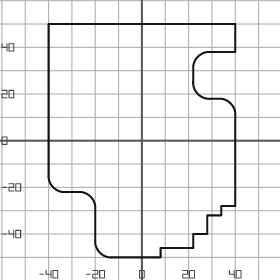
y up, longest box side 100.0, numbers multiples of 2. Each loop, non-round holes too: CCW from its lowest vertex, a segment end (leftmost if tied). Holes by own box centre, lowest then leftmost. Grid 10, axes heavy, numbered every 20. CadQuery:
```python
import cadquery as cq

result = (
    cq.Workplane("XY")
    .moveTo(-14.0, -50.0)
    .lineTo(8.0, -50.0)
    .lineTo(8.0, -46.0)
    .lineTo(22.0, -46.0)
    .lineTo(22.0, -40.0)
    .lineTo(28.0, -40.0)
    .lineTo(28.0, -32.0)
    .lineTo(34.0, -32.0)
    .lineTo(34.0, -28.0)
    .lineTo(40.0, -28.0)
    .lineTo(40.0, 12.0)
    .threePointArc((38.0, 16.0), (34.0, 18.0))
    .lineTo(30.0, 18.0)
    .threePointArc((24.0, 20.0), (22.0, 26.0))
    .lineTo(22.0, 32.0)
    .threePointArc((24.0, 36.0), (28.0, 38.0))
    .lineTo(40.0, 38.0)
    .lineTo(40.0, 50.0)
    .lineTo(-40.0, 50.0)
    .lineTo(-40.0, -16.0)
    .threePointArc((-38.0, -20.0), (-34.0, -22.0))
    .lineTo(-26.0, -22.0)
    .threePointArc((-22.0, -24.0), (-20.0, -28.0))
    .lineTo(-20.0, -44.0)
    .threePointArc((-18.0, -48.0), (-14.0, -50.0))
    .close()
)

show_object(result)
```